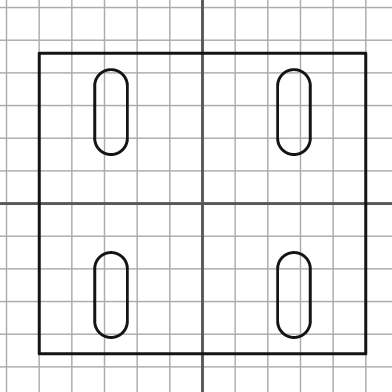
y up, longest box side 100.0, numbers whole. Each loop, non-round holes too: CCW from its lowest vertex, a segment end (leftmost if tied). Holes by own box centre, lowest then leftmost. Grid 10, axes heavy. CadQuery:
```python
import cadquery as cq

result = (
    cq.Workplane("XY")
    .moveTo(-50.0, -46.0)
    .lineTo(50.0, -46.0)
    .lineTo(50.0, 46.0)
    .lineTo(-50.0, 46.0)
    .close()
    .moveTo(-33.0, -36.0)
    .threePointArc((-28.0, -41.0), (-23.0, -36.0))
    .lineTo(-23.0, -20.0)
    .threePointArc((-28.0, -15.0), (-33.0, -20.0))
    .close()
    .moveTo(23.0, -36.0)
    .threePointArc((28.0, -41.0), (33.0, -36.0))
    .lineTo(33.0, -20.0)
    .threePointArc((28.0, -15.0), (23.0, -20.0))
    .close()
    .moveTo(-33.0, 20.0)
    .threePointArc((-28.0, 15.0), (-23.0, 20.0))
    .lineTo(-23.0, 36.0)
    .threePointArc((-28.0, 41.0), (-33.0, 36.0))
    .close()
    .moveTo(23.0, 20.0)
    .threePointArc((28.0, 15.0), (33.0, 20.0))
    .lineTo(33.0, 36.0)
    .threePointArc((28.0, 41.0), (23.0, 36.0))
    .close()
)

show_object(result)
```